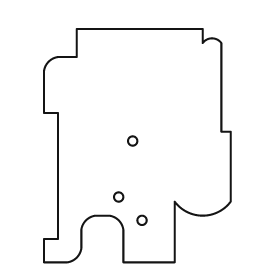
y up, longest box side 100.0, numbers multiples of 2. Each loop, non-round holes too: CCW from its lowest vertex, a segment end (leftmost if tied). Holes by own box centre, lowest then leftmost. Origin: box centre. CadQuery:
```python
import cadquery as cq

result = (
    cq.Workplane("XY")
    .moveTo(-40.0, -50.0)
    .lineTo(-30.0, -50.0)
    .threePointArc((-26.0, -48.0), (-24.0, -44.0))
    .lineTo(-24.0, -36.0)
    .threePointArc((-22.0, -32.0), (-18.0, -30.0))
    .lineTo(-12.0, -30.0)
    .threePointArc((-8.0, -32.0), (-6.0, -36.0))
    .lineTo(-6.0, -50.0)
    .lineTo(16.0, -50.0)
    .lineTo(16.0, -24.0)
    .threePointArc((28.0, -30.0), (40.0, -24.0))
    .lineTo(40.0, 6.0)
    .lineTo(36.0, 6.0)
    .lineTo(36.0, 44.0)
    .threePointArc((32.0, 46.0), (28.0, 44.0))
    .lineTo(28.0, 50.0)
    .lineTo(-26.0, 50.0)
    .lineTo(-26.0, 38.0)
    .lineTo(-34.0, 38.0)
    .threePointArc((-38.0, 36.0), (-40.0, 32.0))
    .lineTo(-40.0, 14.0)
    .lineTo(-34.0, 14.0)
    .lineTo(-34.0, -40.0)
    .lineTo(-40.0, -40.0)
    .close()
    .moveTo(2.0, -32.0)
    .circle(2.0)
    .moveTo(-8.0, -22.0)
    .circle(2.0)
    .moveTo(-2.0, 2.0)
    .circle(2.0)
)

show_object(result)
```